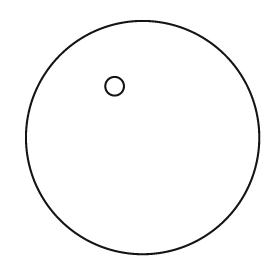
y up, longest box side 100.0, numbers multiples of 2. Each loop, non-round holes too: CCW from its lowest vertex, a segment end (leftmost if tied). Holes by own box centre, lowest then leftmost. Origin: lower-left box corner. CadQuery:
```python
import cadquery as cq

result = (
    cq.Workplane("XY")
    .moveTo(50.0, 50.0)
    .circle(50.0)
    .moveTo(38.0, 72.0)
    .circle(4.0)
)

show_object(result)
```